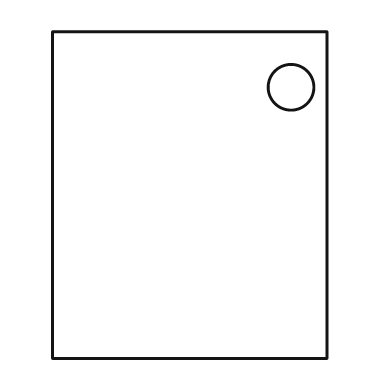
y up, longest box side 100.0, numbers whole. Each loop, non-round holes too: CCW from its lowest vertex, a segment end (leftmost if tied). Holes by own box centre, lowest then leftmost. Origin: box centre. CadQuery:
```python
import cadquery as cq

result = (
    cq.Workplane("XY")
    .moveTo(-42.0, -50.0)
    .lineTo(42.0, -50.0)
    .lineTo(42.0, 50.0)
    .lineTo(-42.0, 50.0)
    .close()
    .moveTo(31.0, 33.0)
    .circle(7.0)
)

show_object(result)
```